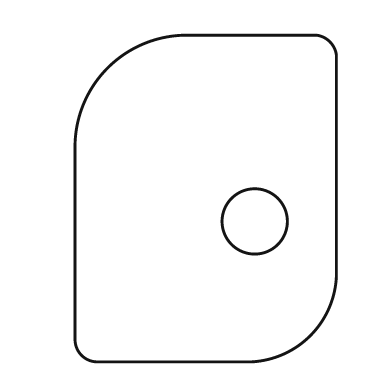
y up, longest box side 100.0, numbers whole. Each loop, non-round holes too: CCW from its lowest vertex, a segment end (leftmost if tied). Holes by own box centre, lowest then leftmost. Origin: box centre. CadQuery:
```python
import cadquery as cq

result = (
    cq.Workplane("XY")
    .moveTo(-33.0, -50.0)
    .lineTo(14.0, -50.0)
    .threePointArc((32.0, -42.0), (40.0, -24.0))
    .lineTo(40.0, 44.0)
    .threePointArc((38.0, 48.0), (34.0, 50.0))
    .lineTo(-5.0, 50.0)
    .threePointArc((-30.0, 40.0), (-40.0, 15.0))
    .lineTo(-40.0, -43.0)
    .threePointArc((-38.0, -48.0), (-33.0, -50.0))
    .close()
    .moveTo(15.0, -7.0)
    .circle(10.0)
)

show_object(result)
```